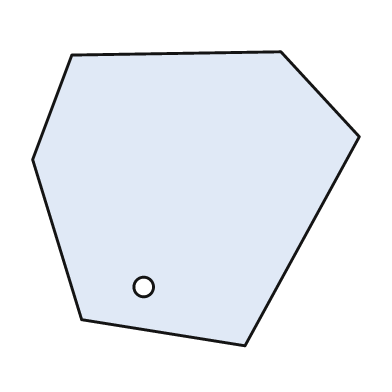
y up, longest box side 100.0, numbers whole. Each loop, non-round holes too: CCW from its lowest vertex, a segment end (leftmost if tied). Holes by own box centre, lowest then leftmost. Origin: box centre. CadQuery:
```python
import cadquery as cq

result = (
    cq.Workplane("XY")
    .moveTo(15.0, -45.0)
    .lineTo(50.0, 19.0)
    .lineTo(26.0, 45.0)
    .lineTo(-38.0, 44.0)
    .lineTo(-50.0, 12.0)
    .lineTo(-35.0, -37.0)
    .close()
    .moveTo(-16.0, -27.0)
    .circle(3.0)
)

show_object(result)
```